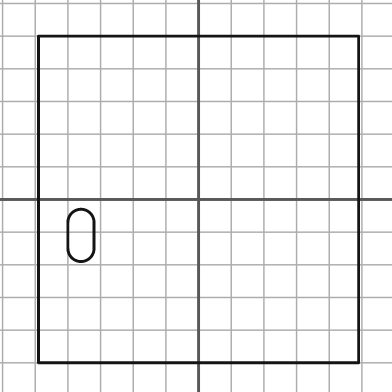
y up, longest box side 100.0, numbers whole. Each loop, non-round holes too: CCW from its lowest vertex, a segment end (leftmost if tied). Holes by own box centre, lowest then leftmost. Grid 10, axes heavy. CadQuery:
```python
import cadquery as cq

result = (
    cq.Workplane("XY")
    .moveTo(-49.0, -50.0)
    .lineTo(49.0, -50.0)
    .lineTo(49.0, 50.0)
    .lineTo(-49.0, 50.0)
    .close()
    .moveTo(-40.0, -15.0)
    .threePointArc((-36.0, -19.0), (-32.0, -15.0))
    .lineTo(-32.0, -7.0)
    .threePointArc((-36.0, -3.0), (-40.0, -7.0))
    .close()
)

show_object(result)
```